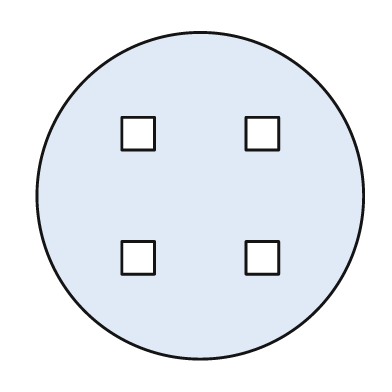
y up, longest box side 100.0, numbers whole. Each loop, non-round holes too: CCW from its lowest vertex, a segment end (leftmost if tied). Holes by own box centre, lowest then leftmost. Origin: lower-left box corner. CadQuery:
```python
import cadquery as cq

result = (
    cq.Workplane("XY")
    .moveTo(50.0, 50.0)
    .circle(50.0)
    .moveTo(26.0, 26.0)
    .lineTo(36.0, 26.0)
    .lineTo(36.0, 36.0)
    .lineTo(26.0, 36.0)
    .close()
    .moveTo(64.0, 26.0)
    .lineTo(74.0, 26.0)
    .lineTo(74.0, 36.0)
    .lineTo(64.0, 36.0)
    .close()
    .moveTo(26.0, 64.0)
    .lineTo(36.0, 64.0)
    .lineTo(36.0, 74.0)
    .lineTo(26.0, 74.0)
    .close()
    .moveTo(64.0, 64.0)
    .lineTo(74.0, 64.0)
    .lineTo(74.0, 74.0)
    .lineTo(64.0, 74.0)
    .close()
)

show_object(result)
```